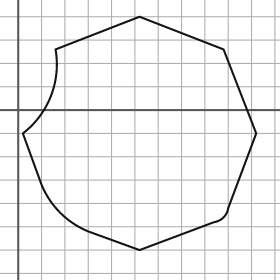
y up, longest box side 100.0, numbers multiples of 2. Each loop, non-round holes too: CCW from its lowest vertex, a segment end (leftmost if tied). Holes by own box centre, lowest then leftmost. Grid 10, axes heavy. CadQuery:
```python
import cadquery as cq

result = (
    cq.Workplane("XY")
    .moveTo(52.0, -60.0)
    .lineTo(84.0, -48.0)
    .threePointArc((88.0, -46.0), (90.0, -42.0))
    .lineTo(102.0, -10.0)
    .lineTo(88.0, 26.0)
    .lineTo(52.0, 40.0)
    .lineTo(16.0, 26.0)
    .threePointArc((14.0, 6.0), (2.0, -10.0))
    .lineTo(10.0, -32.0)
    .threePointArc((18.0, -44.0), (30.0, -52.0))
    .close()
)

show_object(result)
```